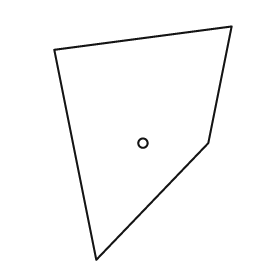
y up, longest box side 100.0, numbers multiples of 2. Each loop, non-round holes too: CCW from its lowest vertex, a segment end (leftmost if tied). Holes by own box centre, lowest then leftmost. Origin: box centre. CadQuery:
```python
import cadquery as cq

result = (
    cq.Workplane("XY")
    .moveTo(-20.0, -50.0)
    .lineTo(28.0, 0.0)
    .lineTo(38.0, 50.0)
    .lineTo(-38.0, 40.0)
    .close()
    .moveTo(0.0, 0.0)
    .circle(2.0)
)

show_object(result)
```